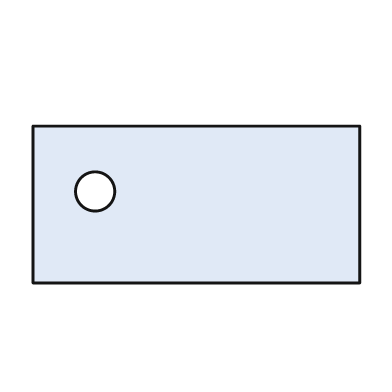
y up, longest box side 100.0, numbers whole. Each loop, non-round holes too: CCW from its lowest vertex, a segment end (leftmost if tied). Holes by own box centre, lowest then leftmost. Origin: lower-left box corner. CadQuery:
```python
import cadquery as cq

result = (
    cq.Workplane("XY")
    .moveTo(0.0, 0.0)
    .lineTo(100.0, 0.0)
    .lineTo(100.0, 48.0)
    .lineTo(0.0, 48.0)
    .close()
    .moveTo(19.0, 28.0)
    .circle(6.0)
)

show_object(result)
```